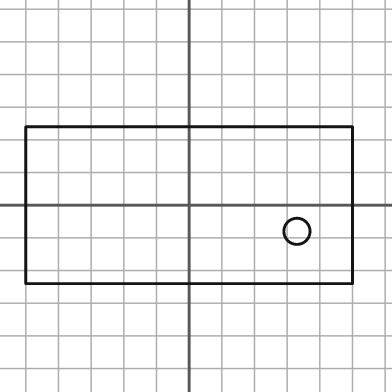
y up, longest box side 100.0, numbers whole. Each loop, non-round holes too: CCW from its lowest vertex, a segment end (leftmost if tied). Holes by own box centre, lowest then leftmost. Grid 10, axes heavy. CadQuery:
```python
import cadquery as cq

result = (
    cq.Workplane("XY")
    .moveTo(-50.0, -24.0)
    .lineTo(50.0, -24.0)
    .lineTo(50.0, 24.0)
    .lineTo(-50.0, 24.0)
    .close()
    .moveTo(33.0, -8.0)
    .circle(4.0)
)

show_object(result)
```